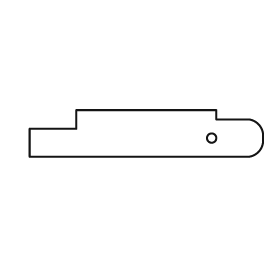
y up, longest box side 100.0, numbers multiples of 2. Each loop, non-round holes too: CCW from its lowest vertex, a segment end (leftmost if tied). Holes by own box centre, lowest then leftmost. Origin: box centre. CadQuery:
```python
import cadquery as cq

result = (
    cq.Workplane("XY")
    .moveTo(-50.0, -10.0)
    .lineTo(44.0, -10.0)
    .threePointArc((48.0, -8.0), (50.0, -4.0))
    .lineTo(50.0, 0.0)
    .threePointArc((48.0, 4.0), (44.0, 6.0))
    .lineTo(30.0, 6.0)
    .lineTo(30.0, 10.0)
    .lineTo(-30.0, 10.0)
    .lineTo(-30.0, 2.0)
    .lineTo(-50.0, 2.0)
    .close()
    .moveTo(28.0, -2.0)
    .circle(2.0)
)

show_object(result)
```